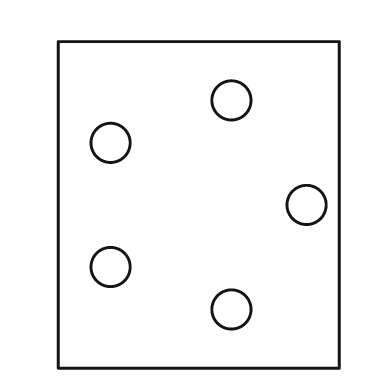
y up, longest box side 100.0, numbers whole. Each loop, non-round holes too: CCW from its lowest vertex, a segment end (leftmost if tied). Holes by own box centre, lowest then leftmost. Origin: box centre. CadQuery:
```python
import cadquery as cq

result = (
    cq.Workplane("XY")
    .moveTo(-43.0, -50.0)
    .lineTo(43.0, -50.0)
    .lineTo(43.0, 50.0)
    .lineTo(-43.0, 50.0)
    .close()
    .moveTo(10.0, -32.0)
    .circle(6.0)
    .moveTo(-27.0, -19.0)
    .circle(6.0)
    .moveTo(33.0, 0.0)
    .circle(6.0)
    .moveTo(-27.0, 19.0)
    .circle(6.0)
    .moveTo(10.0, 32.0)
    .circle(6.0)
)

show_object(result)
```